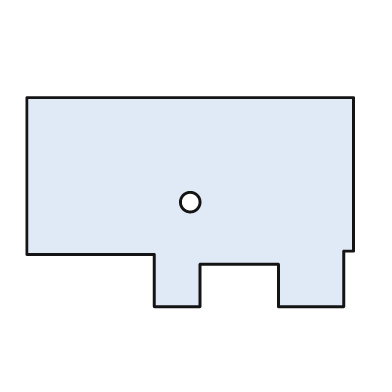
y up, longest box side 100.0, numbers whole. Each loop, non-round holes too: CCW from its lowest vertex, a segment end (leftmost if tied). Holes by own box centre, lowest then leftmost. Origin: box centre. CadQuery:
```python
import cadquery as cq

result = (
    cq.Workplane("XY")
    .moveTo(-11.0, -32.0)
    .lineTo(3.0, -32.0)
    .lineTo(3.0, -19.0)
    .lineTo(27.0, -19.0)
    .lineTo(27.0, -32.0)
    .lineTo(47.0, -32.0)
    .lineTo(47.0, -15.0)
    .lineTo(50.0, -15.0)
    .lineTo(50.0, 32.0)
    .lineTo(-50.0, 32.0)
    .lineTo(-50.0, -16.0)
    .lineTo(-11.0, -16.0)
    .close()
    .moveTo(0.0, 0.0)
    .circle(3.0)
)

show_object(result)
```